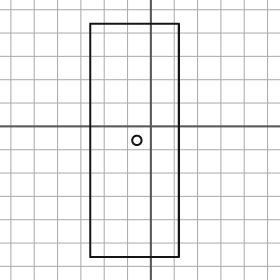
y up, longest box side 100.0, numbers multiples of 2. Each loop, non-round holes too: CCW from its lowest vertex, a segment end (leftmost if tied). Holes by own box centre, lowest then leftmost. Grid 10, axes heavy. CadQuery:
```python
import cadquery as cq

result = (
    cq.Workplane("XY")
    .moveTo(-26.0, -56.0)
    .lineTo(12.0, -56.0)
    .lineTo(12.0, 44.0)
    .lineTo(-26.0, 44.0)
    .close()
    .moveTo(-6.0, -6.0)
    .circle(2.0)
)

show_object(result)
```